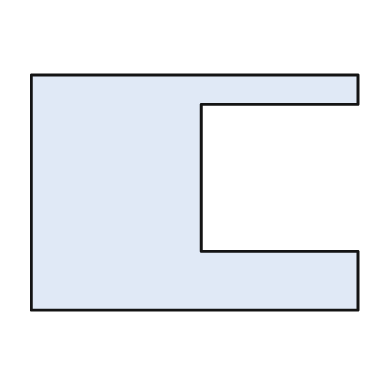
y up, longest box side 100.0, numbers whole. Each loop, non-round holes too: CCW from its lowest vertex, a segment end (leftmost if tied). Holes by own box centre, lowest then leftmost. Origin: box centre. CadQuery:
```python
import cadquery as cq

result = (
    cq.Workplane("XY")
    .moveTo(-50.0, -36.0)
    .lineTo(50.0, -36.0)
    .lineTo(50.0, -18.0)
    .lineTo(2.0, -18.0)
    .lineTo(2.0, 27.0)
    .lineTo(50.0, 27.0)
    .lineTo(50.0, 36.0)
    .lineTo(-50.0, 36.0)
    .close()
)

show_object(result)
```